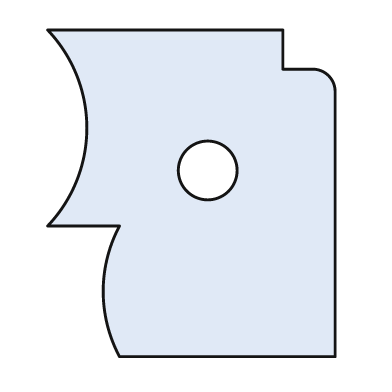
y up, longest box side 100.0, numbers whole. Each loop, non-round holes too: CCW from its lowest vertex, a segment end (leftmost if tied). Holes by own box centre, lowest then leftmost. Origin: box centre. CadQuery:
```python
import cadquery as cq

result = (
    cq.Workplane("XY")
    .moveTo(-22.0, -50.0)
    .lineTo(44.0, -50.0)
    .lineTo(44.0, 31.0)
    .threePointArc((42.0, 36.0), (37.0, 38.0))
    .lineTo(28.0, 38.0)
    .lineTo(28.0, 50.0)
    .lineTo(-44.0, 50.0)
    .threePointArc((-32.0, 20.0), (-44.0, -10.0))
    .lineTo(-22.0, -10.0)
    .threePointArc((-27.0, -30.0), (-22.0, -50.0))
    .close()
    .moveTo(5.0, 7.0)
    .circle(9.0)
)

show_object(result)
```